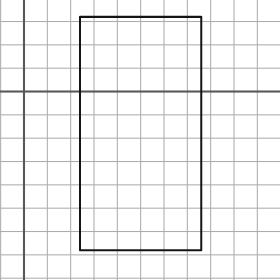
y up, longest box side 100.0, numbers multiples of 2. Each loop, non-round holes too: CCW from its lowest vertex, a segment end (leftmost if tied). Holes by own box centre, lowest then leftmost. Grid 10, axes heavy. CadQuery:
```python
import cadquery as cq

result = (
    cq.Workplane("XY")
    .moveTo(24.0, -68.0)
    .lineTo(76.0, -68.0)
    .lineTo(76.0, 32.0)
    .lineTo(24.0, 32.0)
    .close()
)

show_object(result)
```